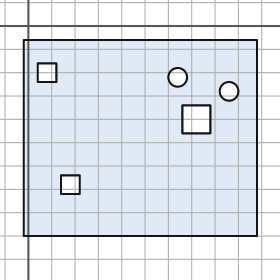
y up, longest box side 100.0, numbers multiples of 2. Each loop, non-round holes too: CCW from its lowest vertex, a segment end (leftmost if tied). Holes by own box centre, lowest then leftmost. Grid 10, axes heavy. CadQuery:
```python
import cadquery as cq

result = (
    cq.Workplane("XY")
    .moveTo(-2.0, -90.0)
    .lineTo(98.0, -90.0)
    .lineTo(98.0, -6.0)
    .lineTo(-2.0, -6.0)
    .close()
    .moveTo(14.0, -72.0)
    .lineTo(22.0, -72.0)
    .lineTo(22.0, -64.0)
    .lineTo(14.0, -64.0)
    .close()
    .moveTo(66.0, -46.0)
    .lineTo(78.0, -46.0)
    .lineTo(78.0, -34.0)
    .lineTo(66.0, -34.0)
    .close()
    .moveTo(86.0, -28.0)
    .circle(4.0)
    .moveTo(64.0, -22.0)
    .circle(4.0)
    .moveTo(4.0, -24.0)
    .lineTo(12.0, -24.0)
    .lineTo(12.0, -16.0)
    .lineTo(4.0, -16.0)
    .close()
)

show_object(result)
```